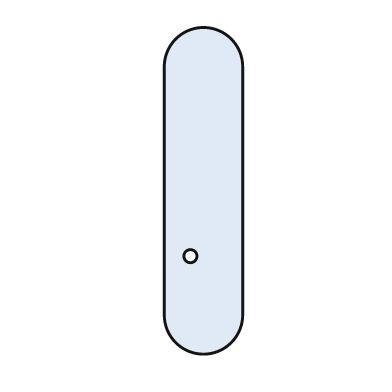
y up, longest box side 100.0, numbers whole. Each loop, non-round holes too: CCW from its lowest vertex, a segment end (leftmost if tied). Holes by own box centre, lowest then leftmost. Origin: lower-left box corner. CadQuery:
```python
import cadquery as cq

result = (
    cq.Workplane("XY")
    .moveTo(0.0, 12.0)
    .threePointArc((12.0, 0.0), (24.0, 12.0))
    .lineTo(24.0, 88.0)
    .threePointArc((12.0, 100.0), (0.0, 88.0))
    .close()
    .moveTo(8.0, 30.0)
    .circle(2.0)
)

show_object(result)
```